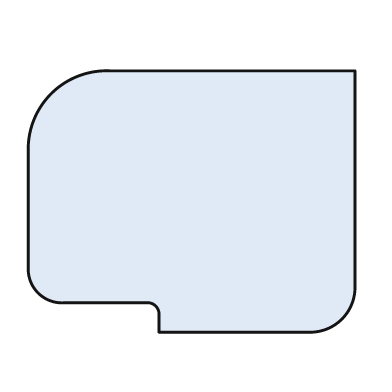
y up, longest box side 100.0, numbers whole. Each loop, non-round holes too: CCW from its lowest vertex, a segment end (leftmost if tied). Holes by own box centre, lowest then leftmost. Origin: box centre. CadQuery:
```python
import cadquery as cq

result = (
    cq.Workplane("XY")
    .moveTo(-10.0, -40.0)
    .lineTo(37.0, -40.0)
    .threePointArc((46.0, -36.0), (50.0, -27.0))
    .lineTo(50.0, 40.0)
    .lineTo(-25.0, 40.0)
    .threePointArc((-43.0, 33.0), (-50.0, 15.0))
    .lineTo(-50.0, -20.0)
    .threePointArc((-47.0, -28.0), (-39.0, -31.0))
    .lineTo(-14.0, -31.0)
    .threePointArc((-11.0, -32.0), (-10.0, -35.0))
    .close()
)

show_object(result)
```